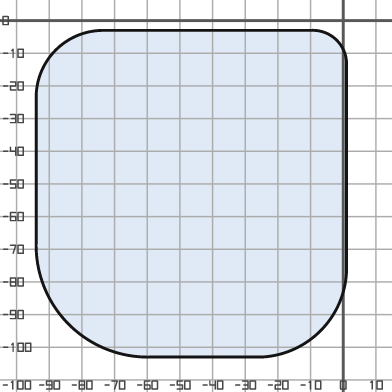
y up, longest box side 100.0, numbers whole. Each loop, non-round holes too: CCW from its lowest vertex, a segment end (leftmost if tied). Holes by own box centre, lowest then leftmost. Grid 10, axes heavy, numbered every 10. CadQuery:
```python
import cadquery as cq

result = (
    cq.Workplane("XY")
    .moveTo(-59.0, -103.0)
    .lineTo(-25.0, -103.0)
    .threePointArc((-7.0, -95.0), (1.0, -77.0))
    .lineTo(1.0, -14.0)
    .threePointArc((-2.0, -6.0), (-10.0, -3.0))
    .lineTo(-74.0, -3.0)
    .threePointArc((-88.0, -9.0), (-94.0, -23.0))
    .lineTo(-94.0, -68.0)
    .threePointArc((-84.0, -93.0), (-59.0, -103.0))
    .close()
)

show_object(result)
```